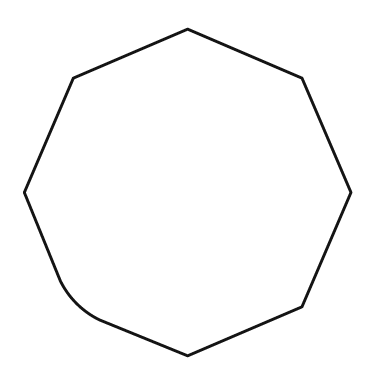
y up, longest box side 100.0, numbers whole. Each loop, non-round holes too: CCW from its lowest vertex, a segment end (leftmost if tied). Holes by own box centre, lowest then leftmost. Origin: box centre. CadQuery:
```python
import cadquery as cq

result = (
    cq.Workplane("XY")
    .moveTo(0.0, -50.0)
    .lineTo(35.0, -35.0)
    .lineTo(50.0, 0.0)
    .lineTo(35.0, 35.0)
    .lineTo(0.0, 50.0)
    .lineTo(-35.0, 35.0)
    .lineTo(-50.0, 0.0)
    .lineTo(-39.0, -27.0)
    .threePointArc((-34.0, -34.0), (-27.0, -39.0))
    .close()
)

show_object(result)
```